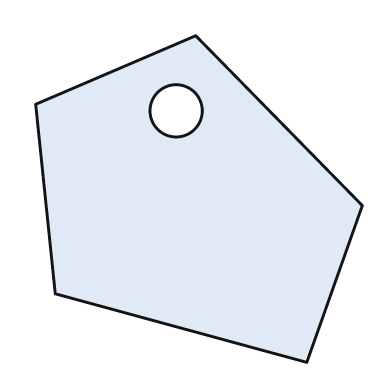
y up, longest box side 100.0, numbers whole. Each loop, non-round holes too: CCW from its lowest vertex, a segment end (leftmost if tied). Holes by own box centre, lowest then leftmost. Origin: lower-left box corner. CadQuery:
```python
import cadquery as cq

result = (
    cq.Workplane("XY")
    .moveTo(83.0, 0.0)
    .lineTo(100.0, 48.0)
    .lineTo(49.0, 100.0)
    .lineTo(0.0, 79.0)
    .lineTo(6.0, 21.0)
    .close()
    .moveTo(43.0, 77.0)
    .circle(8.0)
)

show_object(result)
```